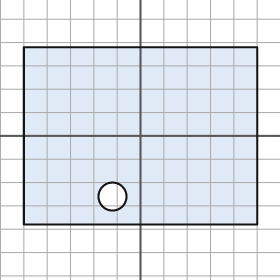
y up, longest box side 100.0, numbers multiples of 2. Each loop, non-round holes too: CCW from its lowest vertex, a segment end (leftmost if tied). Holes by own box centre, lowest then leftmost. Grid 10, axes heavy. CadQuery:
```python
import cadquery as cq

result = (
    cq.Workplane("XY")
    .moveTo(-50.0, -38.0)
    .lineTo(50.0, -38.0)
    .lineTo(50.0, 38.0)
    .lineTo(-50.0, 38.0)
    .close()
    .moveTo(-12.0, -26.0)
    .circle(6.0)
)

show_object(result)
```